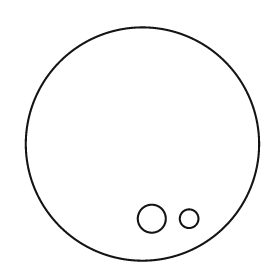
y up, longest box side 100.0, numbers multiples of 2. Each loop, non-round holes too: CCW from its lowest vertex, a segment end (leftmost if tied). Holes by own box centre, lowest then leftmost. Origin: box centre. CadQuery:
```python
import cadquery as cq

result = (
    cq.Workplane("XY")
    .moveTo(0.0, 0.0)
    .circle(50.0)
    .moveTo(4.0, -32.0)
    .circle(6.0)
    .moveTo(20.0, -32.0)
    .circle(4.0)
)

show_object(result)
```